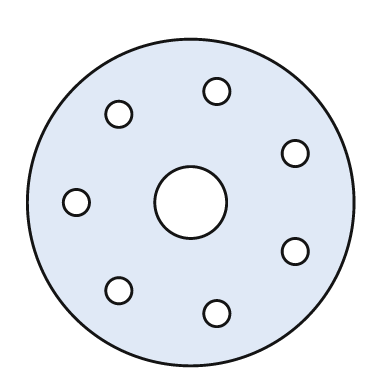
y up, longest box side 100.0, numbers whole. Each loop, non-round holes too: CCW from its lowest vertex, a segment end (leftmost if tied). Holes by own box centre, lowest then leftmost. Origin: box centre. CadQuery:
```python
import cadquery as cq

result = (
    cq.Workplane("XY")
    .moveTo(0.0, 0.0)
    .circle(50.0)
    .moveTo(8.0, -34.0)
    .circle(4.0)
    .moveTo(-22.0, -27.0)
    .circle(4.0)
    .moveTo(32.0, -15.0)
    .circle(4.0)
    .moveTo(-35.0, 0.0)
    .circle(4.0)
    .moveTo(0.0, 0.0)
    .circle(11.0)
    .moveTo(32.0, 15.0)
    .circle(4.0)
    .moveTo(-22.0, 27.0)
    .circle(4.0)
    .moveTo(8.0, 34.0)
    .circle(4.0)
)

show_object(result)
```